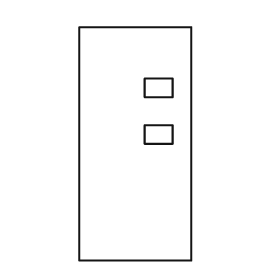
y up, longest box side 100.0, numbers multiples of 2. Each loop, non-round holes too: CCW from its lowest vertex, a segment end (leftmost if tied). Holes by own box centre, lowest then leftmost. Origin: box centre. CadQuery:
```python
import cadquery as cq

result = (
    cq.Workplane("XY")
    .moveTo(-24.0, -50.0)
    .lineTo(24.0, -50.0)
    .lineTo(24.0, 50.0)
    .lineTo(-24.0, 50.0)
    .close()
    .moveTo(4.0, 0.0)
    .lineTo(16.0, 0.0)
    .lineTo(16.0, 8.0)
    .lineTo(4.0, 8.0)
    .close()
    .moveTo(4.0, 20.0)
    .lineTo(16.0, 20.0)
    .lineTo(16.0, 28.0)
    .lineTo(4.0, 28.0)
    .close()
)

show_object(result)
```